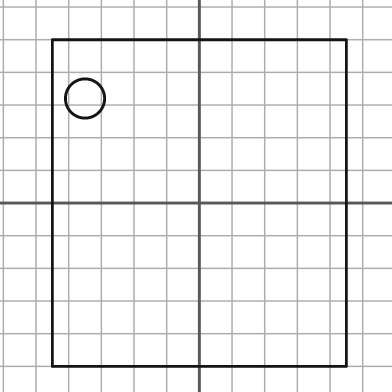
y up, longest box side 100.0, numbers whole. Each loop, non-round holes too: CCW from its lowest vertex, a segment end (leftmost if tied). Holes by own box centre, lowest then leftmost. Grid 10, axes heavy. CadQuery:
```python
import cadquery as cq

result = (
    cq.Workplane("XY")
    .moveTo(-45.0, -50.0)
    .lineTo(45.0, -50.0)
    .lineTo(45.0, 50.0)
    .lineTo(-45.0, 50.0)
    .close()
    .moveTo(-35.0, 32.0)
    .circle(6.0)
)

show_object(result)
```